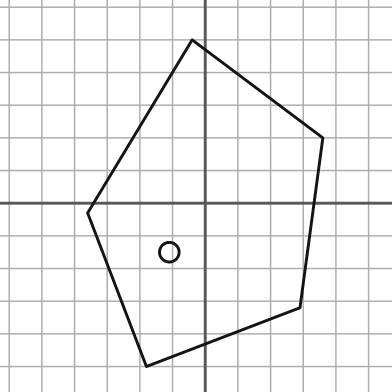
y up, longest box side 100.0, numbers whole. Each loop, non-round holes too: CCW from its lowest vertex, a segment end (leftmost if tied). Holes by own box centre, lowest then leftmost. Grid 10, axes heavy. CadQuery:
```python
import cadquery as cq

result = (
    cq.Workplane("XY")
    .moveTo(-18.0, -50.0)
    .lineTo(29.0, -32.0)
    .lineTo(36.0, 20.0)
    .lineTo(-4.0, 50.0)
    .lineTo(-36.0, -3.0)
    .close()
    .moveTo(-11.0, -15.0)
    .circle(3.0)
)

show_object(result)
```